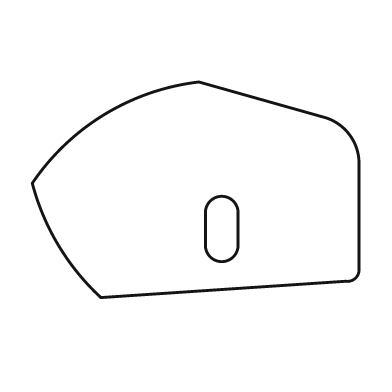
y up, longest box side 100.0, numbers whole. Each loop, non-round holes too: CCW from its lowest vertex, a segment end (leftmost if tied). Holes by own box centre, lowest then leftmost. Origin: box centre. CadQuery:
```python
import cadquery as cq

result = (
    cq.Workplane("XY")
    .moveTo(-29.0, -33.0)
    .lineTo(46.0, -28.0)
    .threePointArc((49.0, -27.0), (50.0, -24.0))
    .lineTo(50.0, 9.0)
    .threePointArc((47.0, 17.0), (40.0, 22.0))
    .lineTo(1.0, 33.0)
    .threePointArc((-28.0, 23.0), (-50.0, 2.0))
    .threePointArc((-42.0, -17.0), (-29.0, -33.0))
    .close()
    .moveTo(3.0, -17.0)
    .threePointArc((8.0, -22.0), (13.0, -17.0))
    .lineTo(13.0, -7.0)
    .threePointArc((8.0, -2.0), (3.0, -7.0))
    .close()
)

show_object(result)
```